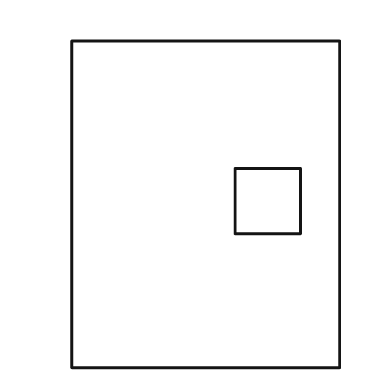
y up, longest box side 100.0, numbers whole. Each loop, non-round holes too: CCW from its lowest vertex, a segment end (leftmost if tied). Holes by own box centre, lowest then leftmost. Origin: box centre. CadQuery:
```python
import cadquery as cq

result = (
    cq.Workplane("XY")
    .moveTo(-41.0, -50.0)
    .lineTo(41.0, -50.0)
    .lineTo(41.0, 50.0)
    .lineTo(-41.0, 50.0)
    .close()
    .moveTo(9.0, -9.0)
    .lineTo(29.0, -9.0)
    .lineTo(29.0, 11.0)
    .lineTo(9.0, 11.0)
    .close()
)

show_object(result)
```